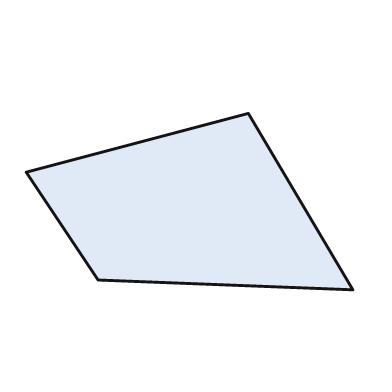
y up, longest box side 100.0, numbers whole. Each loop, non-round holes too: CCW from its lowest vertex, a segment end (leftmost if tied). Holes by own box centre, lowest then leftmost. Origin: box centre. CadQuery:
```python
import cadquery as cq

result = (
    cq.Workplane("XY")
    .moveTo(50.0, -27.0)
    .lineTo(18.0, 27.0)
    .lineTo(-50.0, 9.0)
    .lineTo(-28.0, -24.0)
    .close()
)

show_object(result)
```